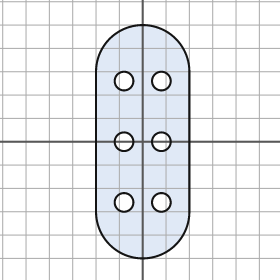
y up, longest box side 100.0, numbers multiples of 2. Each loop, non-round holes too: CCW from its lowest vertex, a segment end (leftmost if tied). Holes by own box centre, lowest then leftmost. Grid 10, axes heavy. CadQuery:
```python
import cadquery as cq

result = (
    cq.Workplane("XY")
    .moveTo(-20.0, -30.0)
    .threePointArc((0.0, -50.0), (20.0, -30.0))
    .lineTo(20.0, 30.0)
    .threePointArc((0.0, 50.0), (-20.0, 30.0))
    .close()
    .moveTo(-8.0, -26.0)
    .circle(4.0)
    .moveTo(8.0, -26.0)
    .circle(4.0)
    .moveTo(-8.0, 0.0)
    .circle(4.0)
    .moveTo(8.0, 0.0)
    .circle(4.0)
    .moveTo(-8.0, 26.0)
    .circle(4.0)
    .moveTo(8.0, 26.0)
    .circle(4.0)
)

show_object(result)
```